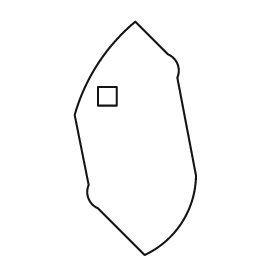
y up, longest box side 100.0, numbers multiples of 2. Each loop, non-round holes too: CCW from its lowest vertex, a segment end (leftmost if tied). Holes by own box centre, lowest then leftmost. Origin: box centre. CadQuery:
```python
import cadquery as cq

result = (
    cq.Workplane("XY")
    .moveTo(4.0, -50.0)
    .threePointArc((20.0, -36.0), (26.0, -16.0))
    .lineTo(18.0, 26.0)
    .threePointArc((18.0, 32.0), (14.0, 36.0))
    .lineTo(0.0, 50.0)
    .threePointArc((-16.0, 32.0), (-26.0, 10.0))
    .lineTo(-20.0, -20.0)
    .threePointArc((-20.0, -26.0), (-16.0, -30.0))
    .close()
    .moveTo(-16.0, 14.0)
    .lineTo(-8.0, 14.0)
    .lineTo(-8.0, 22.0)
    .lineTo(-16.0, 22.0)
    .close()
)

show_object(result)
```